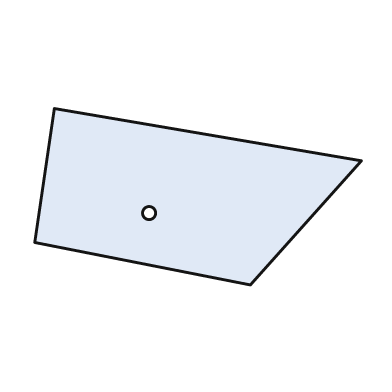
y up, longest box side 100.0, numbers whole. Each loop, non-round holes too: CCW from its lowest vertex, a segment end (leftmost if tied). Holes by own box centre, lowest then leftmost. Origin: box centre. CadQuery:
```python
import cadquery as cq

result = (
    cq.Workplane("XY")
    .moveTo(16.0, -27.0)
    .lineTo(50.0, 11.0)
    .lineTo(-44.0, 27.0)
    .lineTo(-50.0, -14.0)
    .close()
    .moveTo(-15.0, -5.0)
    .circle(2.0)
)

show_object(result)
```